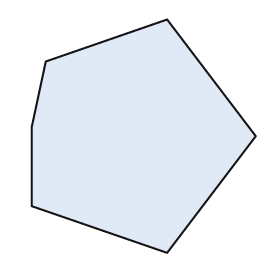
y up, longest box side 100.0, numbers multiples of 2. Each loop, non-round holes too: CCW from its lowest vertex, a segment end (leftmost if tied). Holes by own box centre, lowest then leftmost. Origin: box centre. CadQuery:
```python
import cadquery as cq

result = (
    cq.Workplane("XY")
    .moveTo(10.0, -50.0)
    .lineTo(48.0, 0.0)
    .lineTo(10.0, 50.0)
    .lineTo(-42.0, 32.0)
    .lineTo(-48.0, 4.0)
    .lineTo(-48.0, -30.0)
    .close()
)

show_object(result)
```